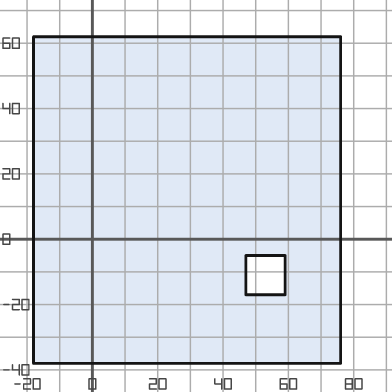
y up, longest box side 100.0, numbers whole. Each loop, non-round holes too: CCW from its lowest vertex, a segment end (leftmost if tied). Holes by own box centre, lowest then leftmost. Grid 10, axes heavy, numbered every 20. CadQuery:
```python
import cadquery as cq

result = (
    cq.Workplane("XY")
    .moveTo(-18.0, -38.0)
    .lineTo(76.0, -38.0)
    .lineTo(76.0, 62.0)
    .lineTo(-18.0, 62.0)
    .close()
    .moveTo(47.0, -17.0)
    .lineTo(59.0, -17.0)
    .lineTo(59.0, -5.0)
    .lineTo(47.0, -5.0)
    .close()
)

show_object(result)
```